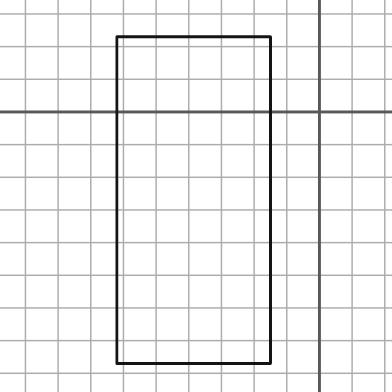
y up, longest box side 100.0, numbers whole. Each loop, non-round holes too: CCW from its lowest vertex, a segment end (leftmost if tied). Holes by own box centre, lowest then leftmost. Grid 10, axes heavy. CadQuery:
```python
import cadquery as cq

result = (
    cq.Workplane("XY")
    .moveTo(-62.0, -77.0)
    .lineTo(-15.0, -77.0)
    .lineTo(-15.0, 23.0)
    .lineTo(-62.0, 23.0)
    .close()
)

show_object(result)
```